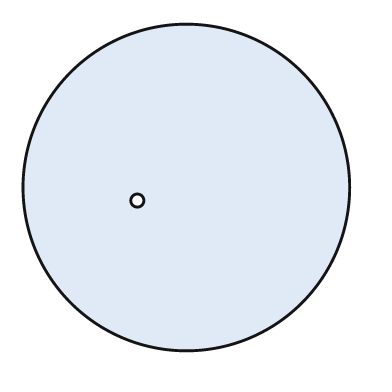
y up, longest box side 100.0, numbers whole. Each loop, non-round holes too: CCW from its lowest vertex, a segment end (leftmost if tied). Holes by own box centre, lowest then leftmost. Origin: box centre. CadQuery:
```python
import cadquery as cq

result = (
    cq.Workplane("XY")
    .moveTo(0.0, 0.0)
    .circle(50.0)
    .moveTo(-15.0, -4.0)
    .circle(2.0)
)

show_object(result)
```